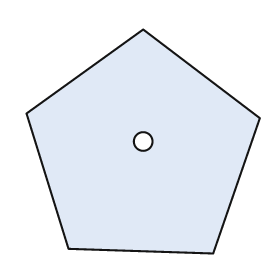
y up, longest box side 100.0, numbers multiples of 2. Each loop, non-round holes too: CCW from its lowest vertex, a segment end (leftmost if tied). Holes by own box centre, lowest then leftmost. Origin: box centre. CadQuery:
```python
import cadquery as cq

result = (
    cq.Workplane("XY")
    .moveTo(30.0, -48.0)
    .lineTo(50.0, 10.0)
    .lineTo(0.0, 48.0)
    .lineTo(-50.0, 12.0)
    .lineTo(-32.0, -46.0)
    .close()
    .moveTo(0.0, 0.0)
    .circle(4.0)
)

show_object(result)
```